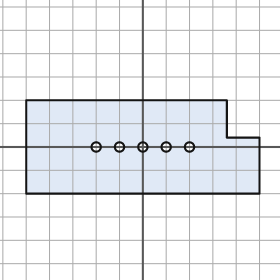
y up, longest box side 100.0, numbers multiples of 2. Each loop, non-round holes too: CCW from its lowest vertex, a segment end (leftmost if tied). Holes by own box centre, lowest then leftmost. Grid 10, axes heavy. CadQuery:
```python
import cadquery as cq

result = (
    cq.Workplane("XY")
    .moveTo(-50.0, -20.0)
    .lineTo(50.0, -20.0)
    .lineTo(50.0, 4.0)
    .lineTo(36.0, 4.0)
    .lineTo(36.0, 20.0)
    .lineTo(-50.0, 20.0)
    .close()
    .moveTo(-20.0, 0.0)
    .circle(2.0)
    .moveTo(-10.0, 0.0)
    .circle(2.0)
    .moveTo(0.0, 0.0)
    .circle(2.0)
    .moveTo(10.0, 0.0)
    .circle(2.0)
    .moveTo(20.0, 0.0)
    .circle(2.0)
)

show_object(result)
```